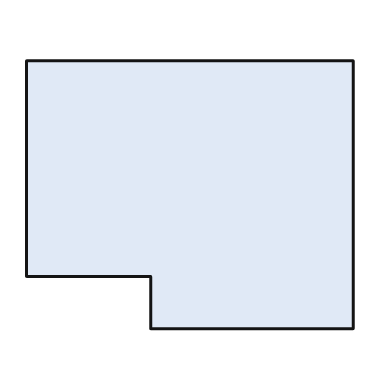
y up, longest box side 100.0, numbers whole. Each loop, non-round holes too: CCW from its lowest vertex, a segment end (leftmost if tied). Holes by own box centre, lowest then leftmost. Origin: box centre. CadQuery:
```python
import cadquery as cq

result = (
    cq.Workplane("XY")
    .moveTo(-12.0, -41.0)
    .lineTo(50.0, -41.0)
    .lineTo(50.0, 41.0)
    .lineTo(-50.0, 41.0)
    .lineTo(-50.0, -25.0)
    .lineTo(-12.0, -25.0)
    .close()
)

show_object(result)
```